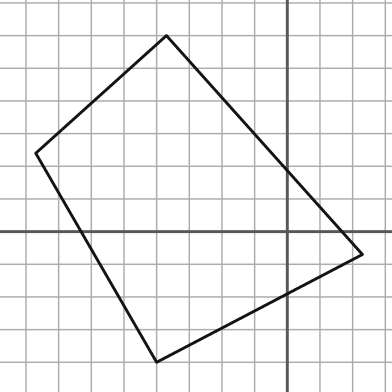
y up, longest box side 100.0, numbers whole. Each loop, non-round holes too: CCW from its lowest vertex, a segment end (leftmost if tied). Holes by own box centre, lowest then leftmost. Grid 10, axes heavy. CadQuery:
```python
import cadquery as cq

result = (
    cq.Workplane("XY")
    .moveTo(-40.0, -40.0)
    .lineTo(23.0, -7.0)
    .lineTo(-37.0, 60.0)
    .lineTo(-77.0, 24.0)
    .close()
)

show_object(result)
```